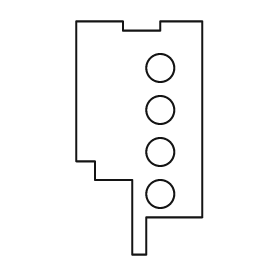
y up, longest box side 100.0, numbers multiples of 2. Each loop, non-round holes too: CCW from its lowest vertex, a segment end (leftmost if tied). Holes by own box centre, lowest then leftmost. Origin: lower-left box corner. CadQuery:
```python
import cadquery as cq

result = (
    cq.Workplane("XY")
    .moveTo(24.0, 0.0)
    .lineTo(30.0, 0.0)
    .lineTo(30.0, 16.0)
    .lineTo(54.0, 16.0)
    .lineTo(54.0, 100.0)
    .lineTo(36.0, 100.0)
    .lineTo(36.0, 96.0)
    .lineTo(20.0, 96.0)
    .lineTo(20.0, 100.0)
    .lineTo(0.0, 100.0)
    .lineTo(0.0, 40.0)
    .lineTo(8.0, 40.0)
    .lineTo(8.0, 32.0)
    .lineTo(24.0, 32.0)
    .close()
    .moveTo(36.0, 26.0)
    .circle(6.0)
    .moveTo(36.0, 44.0)
    .circle(6.0)
    .moveTo(36.0, 62.0)
    .circle(6.0)
    .moveTo(36.0, 80.0)
    .circle(6.0)
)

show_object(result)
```